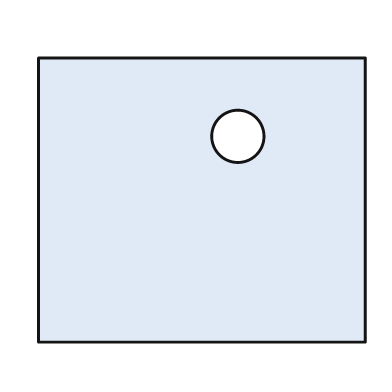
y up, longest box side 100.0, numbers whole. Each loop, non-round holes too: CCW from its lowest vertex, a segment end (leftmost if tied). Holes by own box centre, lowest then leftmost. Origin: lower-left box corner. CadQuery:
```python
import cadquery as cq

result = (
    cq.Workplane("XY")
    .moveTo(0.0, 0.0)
    .lineTo(100.0, 0.0)
    .lineTo(100.0, 87.0)
    .lineTo(0.0, 87.0)
    .close()
    .moveTo(61.0, 63.0)
    .circle(8.0)
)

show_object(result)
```